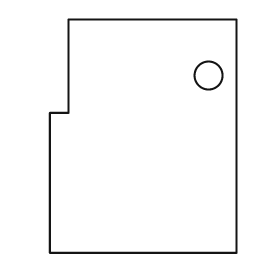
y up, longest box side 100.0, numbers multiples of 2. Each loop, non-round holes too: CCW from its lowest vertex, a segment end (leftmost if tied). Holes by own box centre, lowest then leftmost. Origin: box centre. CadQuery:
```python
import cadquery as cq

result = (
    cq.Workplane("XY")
    .moveTo(-40.0, -50.0)
    .lineTo(40.0, -50.0)
    .lineTo(40.0, 50.0)
    .lineTo(-32.0, 50.0)
    .lineTo(-32.0, 10.0)
    .lineTo(-40.0, 10.0)
    .close()
    .moveTo(28.0, 26.0)
    .circle(6.0)
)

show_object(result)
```